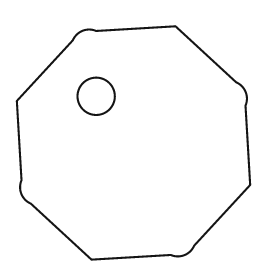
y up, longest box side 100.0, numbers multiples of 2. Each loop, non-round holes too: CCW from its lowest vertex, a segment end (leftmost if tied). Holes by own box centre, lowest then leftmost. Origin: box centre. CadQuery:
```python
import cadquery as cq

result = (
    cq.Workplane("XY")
    .moveTo(-18.0, -50.0)
    .lineTo(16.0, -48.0)
    .threePointArc((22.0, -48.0), (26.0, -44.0))
    .lineTo(50.0, -18.0)
    .lineTo(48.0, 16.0)
    .threePointArc((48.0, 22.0), (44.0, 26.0))
    .lineTo(18.0, 50.0)
    .lineTo(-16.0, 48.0)
    .threePointArc((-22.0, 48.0), (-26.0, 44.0))
    .lineTo(-50.0, 18.0)
    .lineTo(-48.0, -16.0)
    .threePointArc((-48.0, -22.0), (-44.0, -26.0))
    .close()
    .moveTo(-16.0, 20.0)
    .circle(8.0)
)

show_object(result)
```